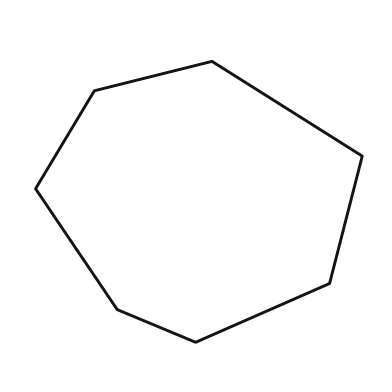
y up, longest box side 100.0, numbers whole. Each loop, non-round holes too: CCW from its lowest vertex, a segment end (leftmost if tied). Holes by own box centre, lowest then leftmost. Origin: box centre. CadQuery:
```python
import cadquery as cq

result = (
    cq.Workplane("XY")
    .moveTo(-1.0, -43.0)
    .lineTo(40.0, -25.0)
    .lineTo(50.0, 14.0)
    .lineTo(4.0, 43.0)
    .lineTo(-32.0, 34.0)
    .lineTo(-50.0, 4.0)
    .lineTo(-25.0, -33.0)
    .close()
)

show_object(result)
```